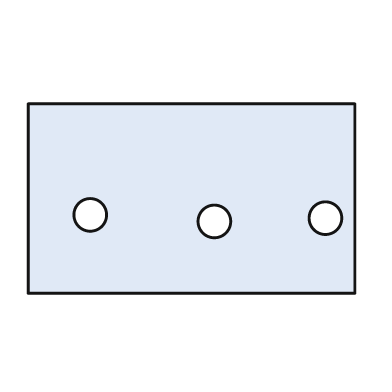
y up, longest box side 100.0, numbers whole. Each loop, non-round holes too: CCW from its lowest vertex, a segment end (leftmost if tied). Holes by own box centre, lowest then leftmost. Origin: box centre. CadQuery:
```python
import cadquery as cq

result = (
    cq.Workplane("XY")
    .moveTo(-50.0, -29.0)
    .lineTo(50.0, -29.0)
    .lineTo(50.0, 29.0)
    .lineTo(-50.0, 29.0)
    .close()
    .moveTo(7.0, -7.0)
    .circle(5.0)
    .moveTo(41.0, -6.0)
    .circle(5.0)
    .moveTo(-31.0, -5.0)
    .circle(5.0)
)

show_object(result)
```